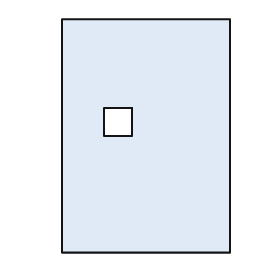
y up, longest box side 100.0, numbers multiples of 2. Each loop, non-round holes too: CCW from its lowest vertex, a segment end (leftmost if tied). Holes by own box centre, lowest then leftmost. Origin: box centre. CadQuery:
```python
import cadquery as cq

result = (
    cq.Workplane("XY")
    .moveTo(-36.0, -50.0)
    .lineTo(36.0, -50.0)
    .lineTo(36.0, 50.0)
    .lineTo(-36.0, 50.0)
    .close()
    .moveTo(-18.0, 0.0)
    .lineTo(-6.0, 0.0)
    .lineTo(-6.0, 12.0)
    .lineTo(-18.0, 12.0)
    .close()
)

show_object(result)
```